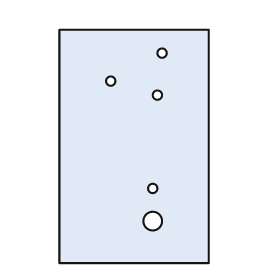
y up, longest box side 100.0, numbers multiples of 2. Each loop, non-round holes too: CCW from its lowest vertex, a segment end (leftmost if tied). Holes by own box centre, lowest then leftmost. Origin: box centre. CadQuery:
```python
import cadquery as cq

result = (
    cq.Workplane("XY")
    .moveTo(-32.0, -50.0)
    .lineTo(32.0, -50.0)
    .lineTo(32.0, 50.0)
    .lineTo(-32.0, 50.0)
    .close()
    .moveTo(8.0, -32.0)
    .circle(4.0)
    .moveTo(8.0, -18.0)
    .circle(2.0)
    .moveTo(10.0, 22.0)
    .circle(2.0)
    .moveTo(-10.0, 28.0)
    .circle(2.0)
    .moveTo(12.0, 40.0)
    .circle(2.0)
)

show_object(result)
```